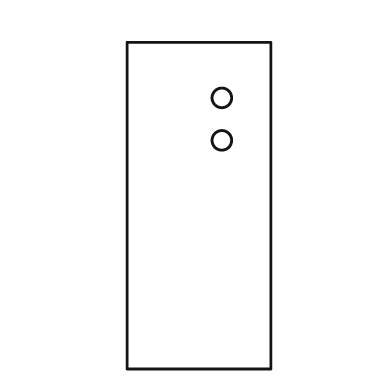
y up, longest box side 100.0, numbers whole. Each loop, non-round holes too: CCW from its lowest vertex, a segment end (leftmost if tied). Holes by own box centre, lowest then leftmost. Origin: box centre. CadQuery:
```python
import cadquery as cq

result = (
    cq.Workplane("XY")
    .moveTo(-22.0, -50.0)
    .lineTo(22.0, -50.0)
    .lineTo(22.0, 50.0)
    .lineTo(-22.0, 50.0)
    .close()
    .moveTo(7.0, 20.0)
    .circle(3.0)
    .moveTo(7.0, 33.0)
    .circle(3.0)
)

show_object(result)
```